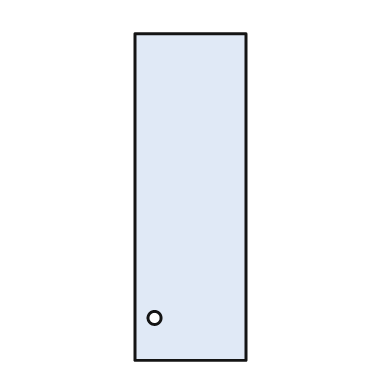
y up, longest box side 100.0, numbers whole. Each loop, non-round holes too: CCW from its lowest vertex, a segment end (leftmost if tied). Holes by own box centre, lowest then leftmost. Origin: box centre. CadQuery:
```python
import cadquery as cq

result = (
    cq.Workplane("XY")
    .moveTo(-17.0, -50.0)
    .lineTo(17.0, -50.0)
    .lineTo(17.0, 50.0)
    .lineTo(-17.0, 50.0)
    .close()
    .moveTo(-11.0, -37.0)
    .circle(2.0)
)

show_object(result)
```